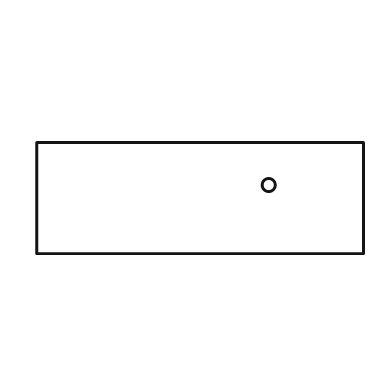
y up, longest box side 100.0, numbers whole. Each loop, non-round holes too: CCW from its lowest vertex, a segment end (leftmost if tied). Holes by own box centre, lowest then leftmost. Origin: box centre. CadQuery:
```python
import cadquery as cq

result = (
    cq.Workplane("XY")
    .moveTo(-50.0, -17.0)
    .lineTo(50.0, -17.0)
    .lineTo(50.0, 17.0)
    .lineTo(-50.0, 17.0)
    .close()
    .moveTo(21.0, 4.0)
    .circle(2.0)
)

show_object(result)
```